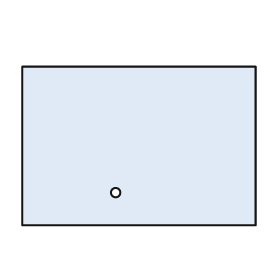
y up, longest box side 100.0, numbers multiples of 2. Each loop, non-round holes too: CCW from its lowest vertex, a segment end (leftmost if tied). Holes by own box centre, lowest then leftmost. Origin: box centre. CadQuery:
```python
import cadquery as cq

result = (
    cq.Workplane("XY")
    .moveTo(-50.0, -34.0)
    .lineTo(50.0, -34.0)
    .lineTo(50.0, 34.0)
    .lineTo(-50.0, 34.0)
    .close()
    .moveTo(-10.0, -20.0)
    .circle(2.0)
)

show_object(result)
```